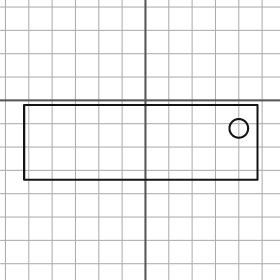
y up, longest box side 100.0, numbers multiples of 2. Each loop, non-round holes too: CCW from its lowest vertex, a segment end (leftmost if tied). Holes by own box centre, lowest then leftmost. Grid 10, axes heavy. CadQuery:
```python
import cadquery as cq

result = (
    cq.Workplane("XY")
    .moveTo(-52.0, -34.0)
    .lineTo(48.0, -34.0)
    .lineTo(48.0, -2.0)
    .lineTo(-52.0, -2.0)
    .close()
    .moveTo(40.0, -12.0)
    .circle(4.0)
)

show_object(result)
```